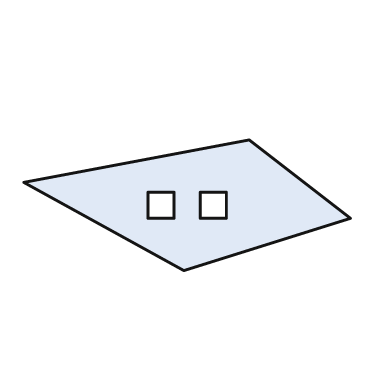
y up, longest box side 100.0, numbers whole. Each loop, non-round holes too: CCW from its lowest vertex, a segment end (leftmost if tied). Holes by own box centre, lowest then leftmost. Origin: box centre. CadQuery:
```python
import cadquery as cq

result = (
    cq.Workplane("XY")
    .moveTo(-1.0, -20.0)
    .lineTo(50.0, -4.0)
    .lineTo(19.0, 20.0)
    .lineTo(-50.0, 7.0)
    .close()
    .moveTo(-12.0, -4.0)
    .lineTo(-4.0, -4.0)
    .lineTo(-4.0, 4.0)
    .lineTo(-12.0, 4.0)
    .close()
    .moveTo(4.0, -4.0)
    .lineTo(12.0, -4.0)
    .lineTo(12.0, 4.0)
    .lineTo(4.0, 4.0)
    .close()
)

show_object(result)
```